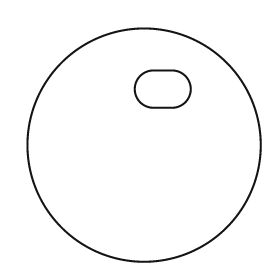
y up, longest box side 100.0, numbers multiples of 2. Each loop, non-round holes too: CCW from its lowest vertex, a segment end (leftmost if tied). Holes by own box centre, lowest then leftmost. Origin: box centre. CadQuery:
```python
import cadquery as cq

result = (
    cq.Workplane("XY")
    .moveTo(0.0, 0.0)
    .circle(50.0)
    .moveTo(4.0, 16.0)
    .lineTo(12.0, 16.0)
    .threePointArc((20.0, 24.0), (12.0, 32.0))
    .lineTo(4.0, 32.0)
    .threePointArc((-4.0, 24.0), (4.0, 16.0))
    .close()
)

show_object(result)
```